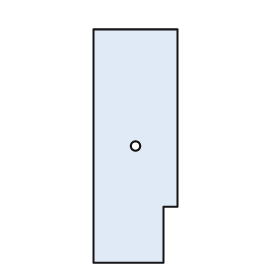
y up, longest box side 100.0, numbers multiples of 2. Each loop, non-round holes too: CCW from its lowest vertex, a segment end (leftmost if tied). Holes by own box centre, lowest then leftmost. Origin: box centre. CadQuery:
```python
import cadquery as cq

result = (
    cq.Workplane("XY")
    .moveTo(-18.0, -50.0)
    .lineTo(12.0, -50.0)
    .lineTo(12.0, -26.0)
    .lineTo(18.0, -26.0)
    .lineTo(18.0, 50.0)
    .lineTo(-18.0, 50.0)
    .close()
    .moveTo(0.0, 0.0)
    .circle(2.0)
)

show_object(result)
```